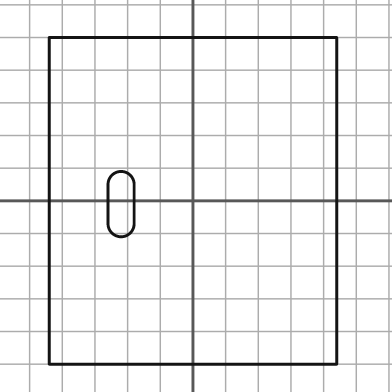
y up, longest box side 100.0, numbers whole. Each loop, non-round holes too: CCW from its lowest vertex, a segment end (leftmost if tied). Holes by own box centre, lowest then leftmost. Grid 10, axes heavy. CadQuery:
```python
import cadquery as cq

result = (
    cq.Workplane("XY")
    .moveTo(-44.0, -50.0)
    .lineTo(44.0, -50.0)
    .lineTo(44.0, 50.0)
    .lineTo(-44.0, 50.0)
    .close()
    .moveTo(-26.0, -7.0)
    .threePointArc((-22.0, -11.0), (-18.0, -7.0))
    .lineTo(-18.0, 5.0)
    .threePointArc((-22.0, 9.0), (-26.0, 5.0))
    .close()
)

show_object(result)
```